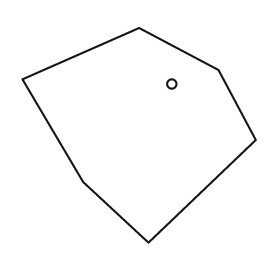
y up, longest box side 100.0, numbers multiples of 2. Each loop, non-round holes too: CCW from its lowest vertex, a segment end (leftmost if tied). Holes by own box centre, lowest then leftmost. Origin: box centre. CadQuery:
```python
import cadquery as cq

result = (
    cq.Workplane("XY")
    .moveTo(4.0, -46.0)
    .lineTo(50.0, -2.0)
    .lineTo(34.0, 28.0)
    .lineTo(0.0, 46.0)
    .lineTo(-50.0, 24.0)
    .lineTo(-24.0, -20.0)
    .close()
    .moveTo(14.0, 22.0)
    .circle(2.0)
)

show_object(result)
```